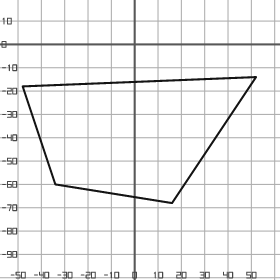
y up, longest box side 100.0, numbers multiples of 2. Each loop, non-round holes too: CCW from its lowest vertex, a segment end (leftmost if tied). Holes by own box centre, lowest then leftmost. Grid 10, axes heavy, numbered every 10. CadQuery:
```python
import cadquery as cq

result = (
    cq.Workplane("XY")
    .moveTo(16.0, -68.0)
    .lineTo(52.0, -14.0)
    .lineTo(-48.0, -18.0)
    .lineTo(-34.0, -60.0)
    .close()
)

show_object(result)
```